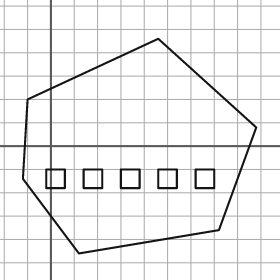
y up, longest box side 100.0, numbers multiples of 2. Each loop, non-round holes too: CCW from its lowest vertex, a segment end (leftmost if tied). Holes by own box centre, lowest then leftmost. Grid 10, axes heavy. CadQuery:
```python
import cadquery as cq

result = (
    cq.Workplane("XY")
    .moveTo(12.0, -46.0)
    .lineTo(72.0, -36.0)
    .lineTo(88.0, 8.0)
    .lineTo(46.0, 46.0)
    .lineTo(-10.0, 20.0)
    .lineTo(-12.0, -14.0)
    .close()
    .moveTo(-2.0, -18.0)
    .lineTo(6.0, -18.0)
    .lineTo(6.0, -10.0)
    .lineTo(-2.0, -10.0)
    .close()
    .moveTo(14.0, -18.0)
    .lineTo(22.0, -18.0)
    .lineTo(22.0, -10.0)
    .lineTo(14.0, -10.0)
    .close()
    .moveTo(30.0, -18.0)
    .lineTo(38.0, -18.0)
    .lineTo(38.0, -10.0)
    .lineTo(30.0, -10.0)
    .close()
    .moveTo(46.0, -18.0)
    .lineTo(54.0, -18.0)
    .lineTo(54.0, -10.0)
    .lineTo(46.0, -10.0)
    .close()
    .moveTo(62.0, -18.0)
    .lineTo(70.0, -18.0)
    .lineTo(70.0, -10.0)
    .lineTo(62.0, -10.0)
    .close()
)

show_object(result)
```